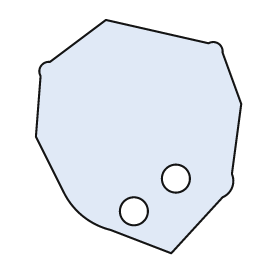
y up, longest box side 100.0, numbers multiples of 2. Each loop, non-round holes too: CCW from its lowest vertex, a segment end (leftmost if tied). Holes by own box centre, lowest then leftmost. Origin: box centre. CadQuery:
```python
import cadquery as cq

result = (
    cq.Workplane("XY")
    .moveTo(14.0, -50.0)
    .lineTo(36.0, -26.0)
    .threePointArc((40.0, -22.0), (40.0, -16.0))
    .lineTo(44.0, 14.0)
    .lineTo(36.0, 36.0)
    .threePointArc((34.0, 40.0), (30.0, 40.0))
    .lineTo(-14.0, 50.0)
    .lineTo(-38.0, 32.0)
    .threePointArc((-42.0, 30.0), (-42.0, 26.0))
    .lineTo(-44.0, 0.0)
    .lineTo(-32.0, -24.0)
    .threePointArc((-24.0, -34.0), (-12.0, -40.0))
    .close()
    .moveTo(-2.0, -32.0)
    .circle(6.0)
    .moveTo(16.0, -18.0)
    .circle(6.0)
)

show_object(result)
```